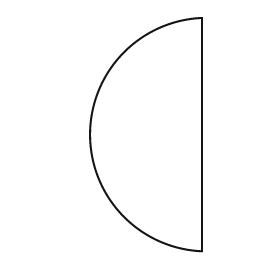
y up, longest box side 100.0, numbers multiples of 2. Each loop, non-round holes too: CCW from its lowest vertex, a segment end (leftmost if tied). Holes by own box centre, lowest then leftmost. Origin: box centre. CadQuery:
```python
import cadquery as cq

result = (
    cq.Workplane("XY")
    .moveTo(24.0, -50.0)
    .lineTo(24.0, 50.0)
    .threePointArc((-24.0, 0.0), (24.0, -50.0))
    .close()
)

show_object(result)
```